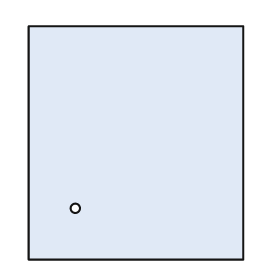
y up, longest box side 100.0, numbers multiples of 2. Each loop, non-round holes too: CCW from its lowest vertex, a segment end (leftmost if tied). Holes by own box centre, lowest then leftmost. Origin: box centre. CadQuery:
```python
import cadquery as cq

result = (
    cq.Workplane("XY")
    .moveTo(-46.0, -50.0)
    .lineTo(46.0, -50.0)
    .lineTo(46.0, 50.0)
    .lineTo(-46.0, 50.0)
    .close()
    .moveTo(-26.0, -28.0)
    .circle(2.0)
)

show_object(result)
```